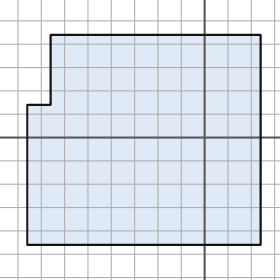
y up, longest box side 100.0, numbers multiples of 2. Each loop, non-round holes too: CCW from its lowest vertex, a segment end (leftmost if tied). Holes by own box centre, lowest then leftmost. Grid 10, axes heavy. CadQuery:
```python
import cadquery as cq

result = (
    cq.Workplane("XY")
    .moveTo(-76.0, -46.0)
    .lineTo(24.0, -46.0)
    .lineTo(24.0, 44.0)
    .lineTo(-66.0, 44.0)
    .lineTo(-66.0, 14.0)
    .lineTo(-76.0, 14.0)
    .close()
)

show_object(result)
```